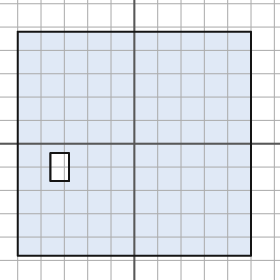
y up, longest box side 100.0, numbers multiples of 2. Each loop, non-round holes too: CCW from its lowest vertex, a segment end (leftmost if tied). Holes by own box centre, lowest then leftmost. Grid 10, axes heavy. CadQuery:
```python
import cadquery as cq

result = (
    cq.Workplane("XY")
    .moveTo(-50.0, -48.0)
    .lineTo(50.0, -48.0)
    .lineTo(50.0, 48.0)
    .lineTo(-50.0, 48.0)
    .close()
    .moveTo(-36.0, -16.0)
    .lineTo(-28.0, -16.0)
    .lineTo(-28.0, -4.0)
    .lineTo(-36.0, -4.0)
    .close()
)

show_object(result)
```